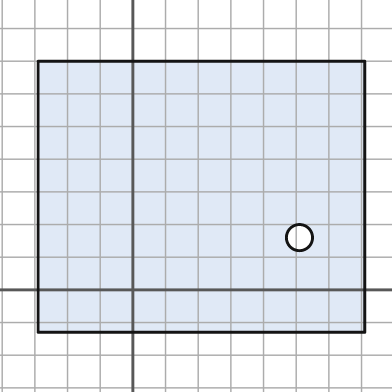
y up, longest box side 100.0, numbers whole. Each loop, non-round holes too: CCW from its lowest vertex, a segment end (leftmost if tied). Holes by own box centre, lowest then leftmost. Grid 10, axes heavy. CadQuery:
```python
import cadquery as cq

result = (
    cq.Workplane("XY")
    .moveTo(-29.0, -13.0)
    .lineTo(71.0, -13.0)
    .lineTo(71.0, 70.0)
    .lineTo(-29.0, 70.0)
    .close()
    .moveTo(51.0, 16.0)
    .circle(4.0)
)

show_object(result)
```